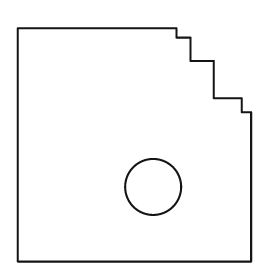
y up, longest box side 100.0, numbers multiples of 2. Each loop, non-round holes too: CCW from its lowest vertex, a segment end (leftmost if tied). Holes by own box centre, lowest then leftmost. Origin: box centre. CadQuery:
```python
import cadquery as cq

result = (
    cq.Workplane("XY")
    .moveTo(-50.0, -50.0)
    .lineTo(50.0, -50.0)
    .lineTo(50.0, 14.0)
    .lineTo(46.0, 14.0)
    .lineTo(46.0, 20.0)
    .lineTo(34.0, 20.0)
    .lineTo(34.0, 36.0)
    .lineTo(24.0, 36.0)
    .lineTo(24.0, 46.0)
    .lineTo(18.0, 46.0)
    .lineTo(18.0, 50.0)
    .lineTo(-50.0, 50.0)
    .close()
    .moveTo(8.0, -18.0)
    .circle(12.0)
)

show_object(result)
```